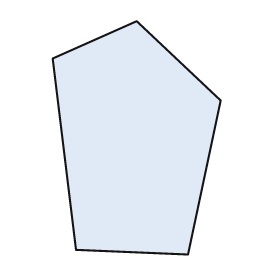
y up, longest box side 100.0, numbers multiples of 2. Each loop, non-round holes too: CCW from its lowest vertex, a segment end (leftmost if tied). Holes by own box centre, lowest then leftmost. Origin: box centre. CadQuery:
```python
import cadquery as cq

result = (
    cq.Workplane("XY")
    .moveTo(22.0, -50.0)
    .lineTo(36.0, 16.0)
    .lineTo(0.0, 50.0)
    .lineTo(-36.0, 34.0)
    .lineTo(-26.0, -48.0)
    .close()
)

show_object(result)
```